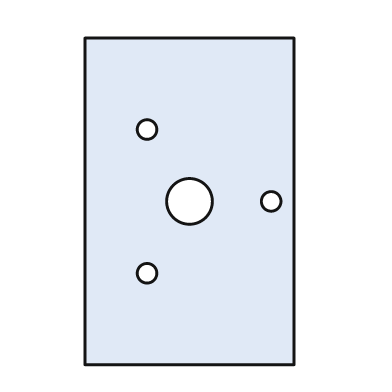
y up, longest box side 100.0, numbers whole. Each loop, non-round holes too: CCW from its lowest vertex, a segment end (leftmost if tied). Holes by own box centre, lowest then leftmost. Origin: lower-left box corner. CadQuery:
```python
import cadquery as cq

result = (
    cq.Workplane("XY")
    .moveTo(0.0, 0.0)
    .lineTo(64.0, 0.0)
    .lineTo(64.0, 100.0)
    .lineTo(0.0, 100.0)
    .close()
    .moveTo(19.0, 28.0)
    .circle(3.0)
    .moveTo(32.0, 50.0)
    .circle(7.0)
    .moveTo(57.0, 50.0)
    .circle(3.0)
    .moveTo(19.0, 72.0)
    .circle(3.0)
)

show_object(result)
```